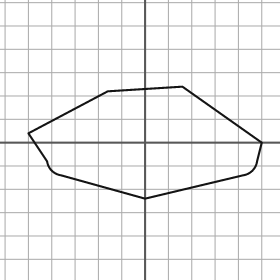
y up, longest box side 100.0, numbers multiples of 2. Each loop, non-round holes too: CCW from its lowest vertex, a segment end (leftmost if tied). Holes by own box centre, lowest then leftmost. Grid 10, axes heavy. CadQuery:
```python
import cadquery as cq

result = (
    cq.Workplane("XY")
    .moveTo(0.0, -24.0)
    .lineTo(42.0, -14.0)
    .threePointArc((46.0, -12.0), (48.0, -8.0))
    .lineTo(50.0, 0.0)
    .lineTo(16.0, 24.0)
    .lineTo(-16.0, 22.0)
    .lineTo(-50.0, 4.0)
    .lineTo(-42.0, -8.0)
    .threePointArc((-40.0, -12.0), (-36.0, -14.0))
    .close()
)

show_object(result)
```